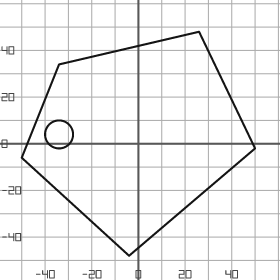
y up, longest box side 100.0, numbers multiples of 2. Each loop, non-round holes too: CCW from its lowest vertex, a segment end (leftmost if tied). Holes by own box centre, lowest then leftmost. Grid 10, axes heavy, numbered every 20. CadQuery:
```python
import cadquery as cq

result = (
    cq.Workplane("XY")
    .moveTo(-4.0, -48.0)
    .lineTo(50.0, -2.0)
    .lineTo(26.0, 48.0)
    .lineTo(-34.0, 34.0)
    .lineTo(-50.0, -6.0)
    .close()
    .moveTo(-34.0, 4.0)
    .circle(6.0)
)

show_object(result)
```